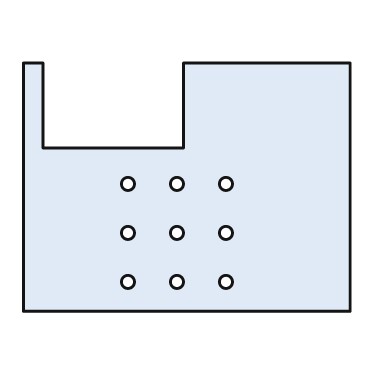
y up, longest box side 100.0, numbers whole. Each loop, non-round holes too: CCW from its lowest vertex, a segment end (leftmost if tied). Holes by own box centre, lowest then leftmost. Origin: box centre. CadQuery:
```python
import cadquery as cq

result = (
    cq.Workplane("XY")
    .moveTo(-50.0, -38.0)
    .lineTo(50.0, -38.0)
    .lineTo(50.0, 38.0)
    .lineTo(-1.0, 38.0)
    .lineTo(-1.0, 12.0)
    .lineTo(-44.0, 12.0)
    .lineTo(-44.0, 38.0)
    .lineTo(-50.0, 38.0)
    .close()
    .moveTo(-18.0, -29.0)
    .circle(2.0)
    .moveTo(-3.0, -29.0)
    .circle(2.0)
    .moveTo(12.0, -29.0)
    .circle(2.0)
    .moveTo(-18.0, -14.0)
    .circle(2.0)
    .moveTo(-3.0, -14.0)
    .circle(2.0)
    .moveTo(12.0, -14.0)
    .circle(2.0)
    .moveTo(-18.0, 1.0)
    .circle(2.0)
    .moveTo(-3.0, 1.0)
    .circle(2.0)
    .moveTo(12.0, 1.0)
    .circle(2.0)
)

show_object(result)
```